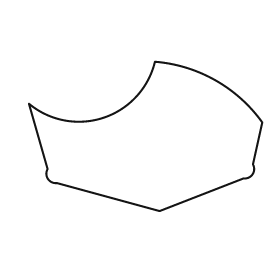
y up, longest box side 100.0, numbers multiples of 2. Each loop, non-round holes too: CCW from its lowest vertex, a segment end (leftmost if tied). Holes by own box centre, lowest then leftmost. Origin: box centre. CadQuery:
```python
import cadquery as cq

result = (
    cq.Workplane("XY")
    .moveTo(6.0, -32.0)
    .lineTo(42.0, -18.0)
    .threePointArc((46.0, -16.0), (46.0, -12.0))
    .lineTo(50.0, 6.0)
    .threePointArc((30.0, 24.0), (4.0, 32.0))
    .threePointArc((-18.0, 8.0), (-50.0, 14.0))
    .lineTo(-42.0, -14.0)
    .threePointArc((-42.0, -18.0), (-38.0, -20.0))
    .close()
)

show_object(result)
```